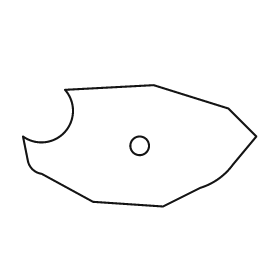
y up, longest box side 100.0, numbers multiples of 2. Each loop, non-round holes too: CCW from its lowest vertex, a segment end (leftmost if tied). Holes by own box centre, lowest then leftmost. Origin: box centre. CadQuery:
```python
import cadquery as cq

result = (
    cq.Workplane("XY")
    .moveTo(10.0, -26.0)
    .lineTo(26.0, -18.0)
    .threePointArc((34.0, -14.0), (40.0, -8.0))
    .lineTo(50.0, 4.0)
    .lineTo(38.0, 16.0)
    .lineTo(6.0, 26.0)
    .lineTo(-32.0, 24.0)
    .threePointArc((-32.0, 6.0), (-50.0, 4.0))
    .lineTo(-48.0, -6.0)
    .threePointArc((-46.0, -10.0), (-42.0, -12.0))
    .lineTo(-20.0, -24.0)
    .close()
    .moveTo(0.0, 0.0)
    .circle(4.0)
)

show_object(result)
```